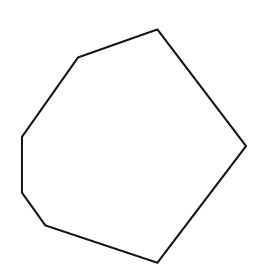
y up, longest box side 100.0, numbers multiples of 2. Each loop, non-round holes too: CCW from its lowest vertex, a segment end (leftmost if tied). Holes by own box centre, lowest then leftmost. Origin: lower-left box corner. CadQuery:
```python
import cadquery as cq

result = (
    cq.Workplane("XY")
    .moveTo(58.0, 0.0)
    .lineTo(96.0, 50.0)
    .lineTo(58.0, 100.0)
    .lineTo(24.0, 88.0)
    .lineTo(0.0, 54.0)
    .lineTo(0.0, 30.0)
    .lineTo(10.0, 16.0)
    .close()
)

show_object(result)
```